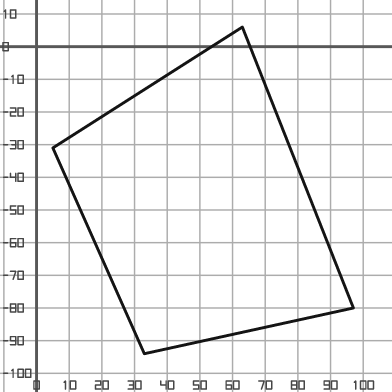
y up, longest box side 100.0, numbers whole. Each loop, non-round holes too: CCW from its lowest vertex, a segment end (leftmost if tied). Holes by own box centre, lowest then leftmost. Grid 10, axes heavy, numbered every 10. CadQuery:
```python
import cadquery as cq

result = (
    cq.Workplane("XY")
    .moveTo(33.0, -94.0)
    .lineTo(97.0, -80.0)
    .lineTo(63.0, 6.0)
    .lineTo(5.0, -31.0)
    .close()
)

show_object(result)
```